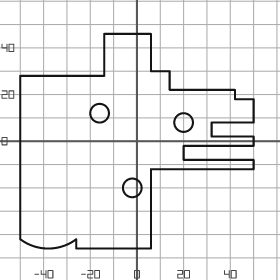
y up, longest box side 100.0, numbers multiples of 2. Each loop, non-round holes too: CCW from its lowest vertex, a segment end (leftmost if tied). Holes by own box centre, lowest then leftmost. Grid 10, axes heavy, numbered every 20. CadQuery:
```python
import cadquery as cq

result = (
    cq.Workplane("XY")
    .moveTo(-26.0, -46.0)
    .lineTo(6.0, -46.0)
    .lineTo(6.0, -12.0)
    .lineTo(50.0, -12.0)
    .lineTo(50.0, -8.0)
    .lineTo(20.0, -8.0)
    .lineTo(20.0, -2.0)
    .lineTo(50.0, -2.0)
    .lineTo(50.0, 2.0)
    .lineTo(32.0, 2.0)
    .lineTo(32.0, 8.0)
    .lineTo(50.0, 8.0)
    .lineTo(50.0, 18.0)
    .lineTo(42.0, 18.0)
    .lineTo(42.0, 22.0)
    .lineTo(14.0, 22.0)
    .lineTo(14.0, 30.0)
    .lineTo(6.0, 30.0)
    .lineTo(6.0, 46.0)
    .lineTo(-14.0, 46.0)
    .lineTo(-14.0, 28.0)
    .lineTo(-50.0, 28.0)
    .lineTo(-50.0, -42.0)
    .threePointArc((-38.0, -46.0), (-26.0, -42.0))
    .close()
    .moveTo(-2.0, -20.0)
    .circle(4.0)
    .moveTo(20.0, 8.0)
    .circle(4.0)
    .moveTo(-16.0, 12.0)
    .circle(4.0)
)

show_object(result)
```